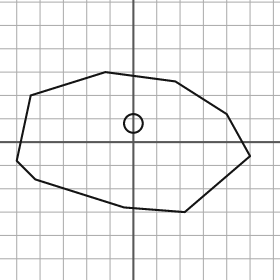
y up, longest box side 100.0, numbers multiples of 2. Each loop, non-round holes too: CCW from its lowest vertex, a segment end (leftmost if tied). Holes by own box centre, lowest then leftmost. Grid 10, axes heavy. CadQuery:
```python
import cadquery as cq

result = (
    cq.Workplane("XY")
    .moveTo(22.0, -30.0)
    .lineTo(50.0, -6.0)
    .lineTo(40.0, 12.0)
    .lineTo(18.0, 26.0)
    .lineTo(-12.0, 30.0)
    .lineTo(-44.0, 20.0)
    .lineTo(-50.0, -8.0)
    .lineTo(-42.0, -16.0)
    .lineTo(-4.0, -28.0)
    .close()
    .moveTo(0.0, 8.0)
    .circle(4.0)
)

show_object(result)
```